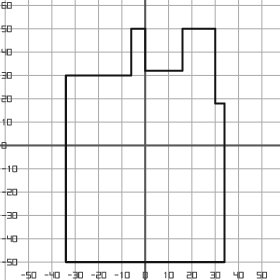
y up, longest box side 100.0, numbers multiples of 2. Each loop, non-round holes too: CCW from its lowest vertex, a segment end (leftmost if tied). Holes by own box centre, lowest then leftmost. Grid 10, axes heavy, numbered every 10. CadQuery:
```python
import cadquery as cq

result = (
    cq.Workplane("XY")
    .moveTo(-34.0, -50.0)
    .lineTo(34.0, -50.0)
    .lineTo(34.0, 18.0)
    .lineTo(30.0, 18.0)
    .lineTo(30.0, 50.0)
    .lineTo(16.0, 50.0)
    .lineTo(16.0, 32.0)
    .lineTo(0.0, 32.0)
    .lineTo(0.0, 50.0)
    .lineTo(-6.0, 50.0)
    .lineTo(-6.0, 30.0)
    .lineTo(-34.0, 30.0)
    .close()
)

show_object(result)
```